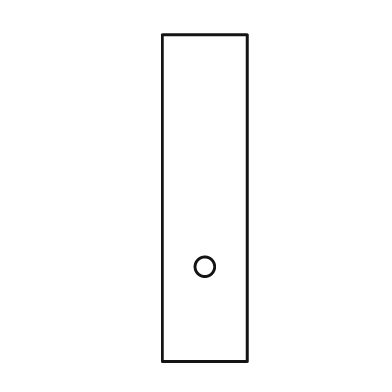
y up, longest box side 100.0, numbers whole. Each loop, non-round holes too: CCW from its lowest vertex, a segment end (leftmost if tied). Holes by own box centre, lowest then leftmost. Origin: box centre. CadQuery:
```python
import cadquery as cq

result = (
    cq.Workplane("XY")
    .moveTo(-13.0, -50.0)
    .lineTo(13.0, -50.0)
    .lineTo(13.0, 50.0)
    .lineTo(-13.0, 50.0)
    .close()
    .moveTo(0.0, -21.0)
    .circle(3.0)
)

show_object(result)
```